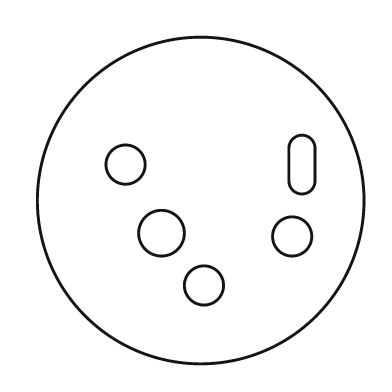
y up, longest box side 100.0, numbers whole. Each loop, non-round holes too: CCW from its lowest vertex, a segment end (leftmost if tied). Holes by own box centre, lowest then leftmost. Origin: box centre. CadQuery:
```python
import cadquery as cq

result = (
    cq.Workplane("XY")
    .moveTo(0.0, 0.0)
    .circle(50.0)
    .moveTo(1.0, -26.0)
    .circle(6.0)
    .moveTo(28.0, -11.0)
    .circle(6.0)
    .moveTo(-12.0, -10.0)
    .circle(7.0)
    .moveTo(-23.0, 11.0)
    .circle(6.0)
    .moveTo(27.0, 6.0)
    .threePointArc((31.0, 2.0), (35.0, 6.0))
    .lineTo(35.0, 16.0)
    .threePointArc((31.0, 20.0), (27.0, 16.0))
    .close()
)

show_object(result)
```